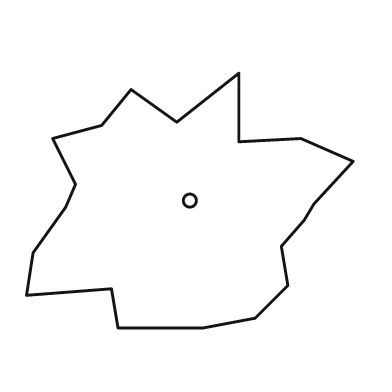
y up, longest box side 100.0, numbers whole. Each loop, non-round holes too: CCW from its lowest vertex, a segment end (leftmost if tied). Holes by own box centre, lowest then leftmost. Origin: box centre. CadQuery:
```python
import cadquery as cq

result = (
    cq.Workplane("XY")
    .moveTo(-22.0, -39.0)
    .lineTo(4.0, -39.0)
    .lineTo(20.0, -36.0)
    .lineTo(30.0, -26.0)
    .lineTo(28.0, -14.0)
    .lineTo(35.0, -6.0)
    .lineTo(38.0, -1.0)
    .lineTo(50.0, 12.0)
    .lineTo(34.0, 19.0)
    .lineTo(15.0, 18.0)
    .lineTo(15.0, 39.0)
    .lineTo(-4.0, 24.0)
    .lineTo(-18.0, 34.0)
    .lineTo(-27.0, 23.0)
    .lineTo(-42.0, 19.0)
    .lineTo(-35.0, 5.0)
    .lineTo(-38.0, -2.0)
    .lineTo(-48.0, -16.0)
    .lineTo(-50.0, -29.0)
    .lineTo(-24.0, -27.0)
    .close()
    .moveTo(0.0, 0.0)
    .circle(2.0)
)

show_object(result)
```